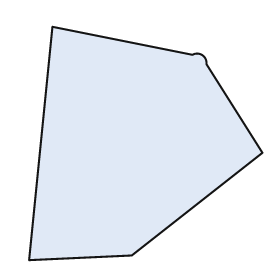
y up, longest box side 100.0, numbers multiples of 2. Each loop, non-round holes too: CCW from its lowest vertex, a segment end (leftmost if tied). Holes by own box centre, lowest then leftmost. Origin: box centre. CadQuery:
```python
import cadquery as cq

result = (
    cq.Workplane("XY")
    .moveTo(-50.0, -50.0)
    .lineTo(-6.0, -48.0)
    .lineTo(50.0, -4.0)
    .lineTo(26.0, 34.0)
    .threePointArc((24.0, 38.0), (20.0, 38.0))
    .lineTo(-40.0, 50.0)
    .close()
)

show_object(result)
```